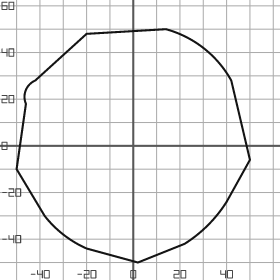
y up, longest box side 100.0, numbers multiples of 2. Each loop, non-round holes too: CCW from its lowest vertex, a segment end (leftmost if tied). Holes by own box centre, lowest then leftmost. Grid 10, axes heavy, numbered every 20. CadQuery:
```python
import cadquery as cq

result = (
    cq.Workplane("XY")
    .moveTo(2.0, -50.0)
    .lineTo(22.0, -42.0)
    .threePointArc((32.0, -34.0), (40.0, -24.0))
    .lineTo(50.0, -6.0)
    .lineTo(42.0, 28.0)
    .threePointArc((30.0, 42.0), (14.0, 50.0))
    .lineTo(-20.0, 48.0)
    .lineTo(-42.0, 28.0)
    .threePointArc((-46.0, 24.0), (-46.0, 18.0))
    .lineTo(-50.0, -10.0)
    .lineTo(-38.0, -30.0)
    .threePointArc((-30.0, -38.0), (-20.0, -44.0))
    .close()
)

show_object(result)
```